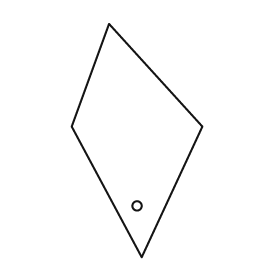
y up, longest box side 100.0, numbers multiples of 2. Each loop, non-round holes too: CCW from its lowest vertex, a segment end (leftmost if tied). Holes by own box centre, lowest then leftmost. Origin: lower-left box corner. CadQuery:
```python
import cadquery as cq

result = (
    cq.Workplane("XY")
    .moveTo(30.0, 0.0)
    .lineTo(56.0, 56.0)
    .lineTo(16.0, 100.0)
    .lineTo(0.0, 56.0)
    .close()
    .moveTo(28.0, 22.0)
    .circle(2.0)
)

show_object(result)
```